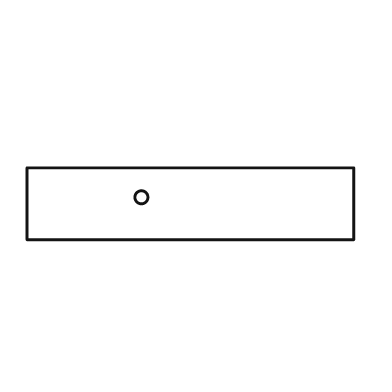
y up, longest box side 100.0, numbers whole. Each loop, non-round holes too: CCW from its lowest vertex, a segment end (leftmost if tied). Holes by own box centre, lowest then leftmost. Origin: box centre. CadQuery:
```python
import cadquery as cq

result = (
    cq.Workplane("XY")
    .moveTo(-50.0, -11.0)
    .lineTo(50.0, -11.0)
    .lineTo(50.0, 11.0)
    .lineTo(-50.0, 11.0)
    .close()
    .moveTo(-15.0, 2.0)
    .circle(2.0)
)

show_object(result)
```